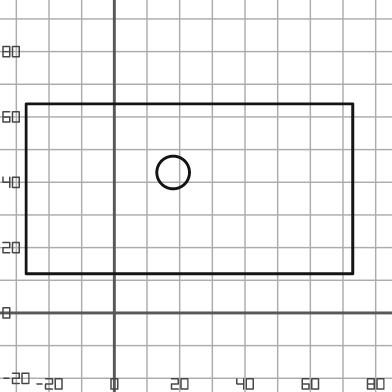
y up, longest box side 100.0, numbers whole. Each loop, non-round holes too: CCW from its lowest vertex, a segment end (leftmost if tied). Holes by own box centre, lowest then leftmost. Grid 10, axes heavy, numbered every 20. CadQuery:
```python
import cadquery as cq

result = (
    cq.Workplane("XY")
    .moveTo(-27.0, 12.0)
    .lineTo(73.0, 12.0)
    .lineTo(73.0, 64.0)
    .lineTo(-27.0, 64.0)
    .close()
    .moveTo(18.0, 43.0)
    .circle(5.0)
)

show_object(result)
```